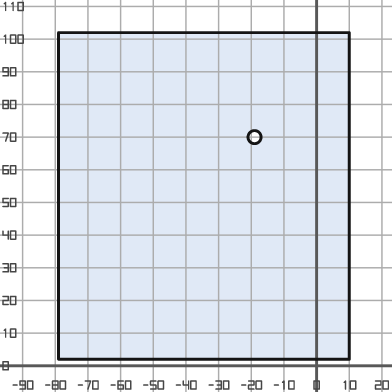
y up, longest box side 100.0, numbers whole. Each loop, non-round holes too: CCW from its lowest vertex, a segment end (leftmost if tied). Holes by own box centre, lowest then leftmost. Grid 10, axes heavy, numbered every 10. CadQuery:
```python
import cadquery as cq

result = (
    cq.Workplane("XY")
    .moveTo(-79.0, 2.0)
    .lineTo(10.0, 2.0)
    .lineTo(10.0, 102.0)
    .lineTo(-79.0, 102.0)
    .close()
    .moveTo(-19.0, 70.0)
    .circle(2.0)
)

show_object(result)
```